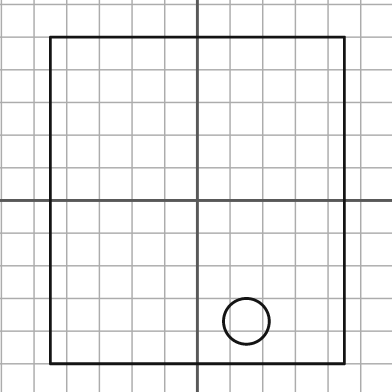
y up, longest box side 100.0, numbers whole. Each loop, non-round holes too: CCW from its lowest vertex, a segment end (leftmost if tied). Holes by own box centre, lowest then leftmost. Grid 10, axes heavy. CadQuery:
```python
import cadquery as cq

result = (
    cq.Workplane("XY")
    .moveTo(-45.0, -50.0)
    .lineTo(45.0, -50.0)
    .lineTo(45.0, 50.0)
    .lineTo(-45.0, 50.0)
    .close()
    .moveTo(15.0, -37.0)
    .circle(7.0)
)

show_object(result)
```